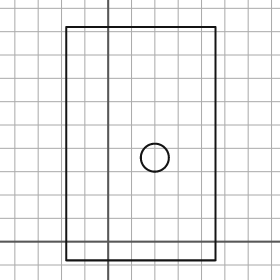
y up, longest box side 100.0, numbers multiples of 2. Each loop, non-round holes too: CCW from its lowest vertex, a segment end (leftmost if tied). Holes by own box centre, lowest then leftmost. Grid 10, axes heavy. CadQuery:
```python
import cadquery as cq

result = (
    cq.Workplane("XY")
    .moveTo(-18.0, -8.0)
    .lineTo(46.0, -8.0)
    .lineTo(46.0, 92.0)
    .lineTo(-18.0, 92.0)
    .close()
    .moveTo(20.0, 36.0)
    .circle(6.0)
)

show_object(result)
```